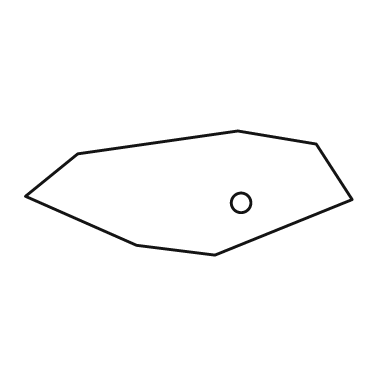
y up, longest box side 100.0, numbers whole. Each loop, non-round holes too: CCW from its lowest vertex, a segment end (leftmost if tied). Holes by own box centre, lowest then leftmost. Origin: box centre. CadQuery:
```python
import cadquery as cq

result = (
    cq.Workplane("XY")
    .moveTo(8.0, -19.0)
    .lineTo(50.0, -2.0)
    .lineTo(39.0, 15.0)
    .lineTo(15.0, 19.0)
    .lineTo(-34.0, 12.0)
    .lineTo(-50.0, -1.0)
    .lineTo(-16.0, -16.0)
    .close()
    .moveTo(16.0, -3.0)
    .circle(3.0)
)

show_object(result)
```